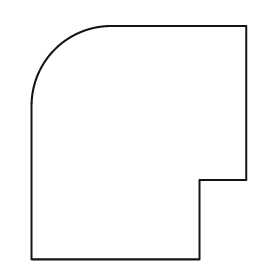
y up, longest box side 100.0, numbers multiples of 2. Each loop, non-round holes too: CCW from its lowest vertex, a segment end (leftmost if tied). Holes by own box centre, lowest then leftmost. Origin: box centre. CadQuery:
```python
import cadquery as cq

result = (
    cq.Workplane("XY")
    .moveTo(-46.0, -50.0)
    .lineTo(26.0, -50.0)
    .lineTo(26.0, -16.0)
    .lineTo(46.0, -16.0)
    .lineTo(46.0, 50.0)
    .lineTo(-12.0, 50.0)
    .threePointArc((-36.0, 40.0), (-46.0, 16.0))
    .close()
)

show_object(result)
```